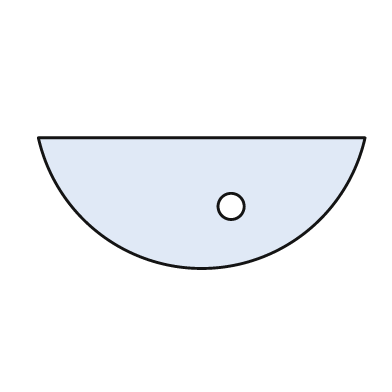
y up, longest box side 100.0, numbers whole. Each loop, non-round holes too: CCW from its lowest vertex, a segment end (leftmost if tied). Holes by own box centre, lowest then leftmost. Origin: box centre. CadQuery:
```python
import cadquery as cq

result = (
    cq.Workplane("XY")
    .moveTo(-50.0, 20.0)
    .threePointArc((0.0, -20.0), (50.0, 20.0))
    .close()
    .moveTo(9.0, -1.0)
    .circle(4.0)
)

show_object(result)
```